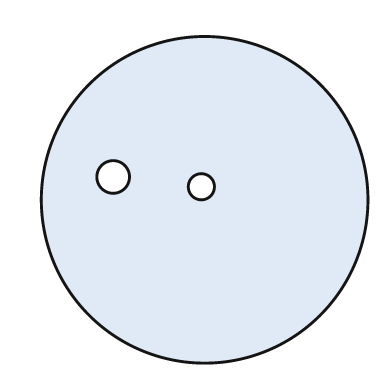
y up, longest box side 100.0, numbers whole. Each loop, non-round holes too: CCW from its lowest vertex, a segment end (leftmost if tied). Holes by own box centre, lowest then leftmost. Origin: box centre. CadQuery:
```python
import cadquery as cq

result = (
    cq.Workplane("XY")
    .moveTo(0.0, 0.0)
    .circle(50.0)
    .moveTo(-1.0, 4.0)
    .circle(4.0)
    .moveTo(-28.0, 7.0)
    .circle(5.0)
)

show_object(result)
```